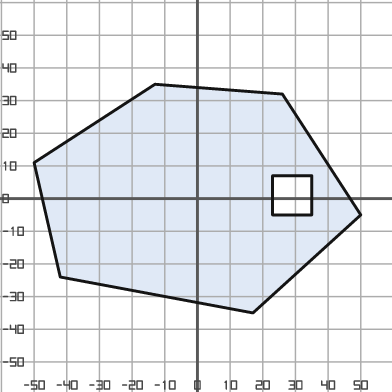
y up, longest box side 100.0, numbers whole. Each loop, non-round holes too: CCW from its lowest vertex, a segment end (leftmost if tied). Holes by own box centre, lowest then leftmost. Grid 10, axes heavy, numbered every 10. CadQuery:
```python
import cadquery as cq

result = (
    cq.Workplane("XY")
    .moveTo(17.0, -35.0)
    .lineTo(50.0, -5.0)
    .lineTo(26.0, 32.0)
    .lineTo(-13.0, 35.0)
    .lineTo(-50.0, 11.0)
    .lineTo(-42.0, -24.0)
    .close()
    .moveTo(23.0, -5.0)
    .lineTo(35.0, -5.0)
    .lineTo(35.0, 7.0)
    .lineTo(23.0, 7.0)
    .close()
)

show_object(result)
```